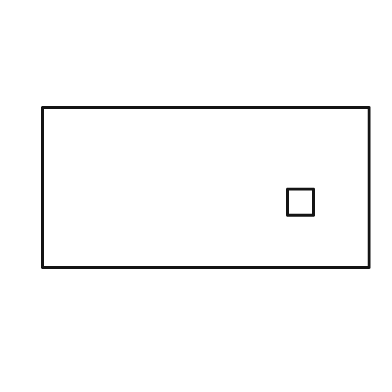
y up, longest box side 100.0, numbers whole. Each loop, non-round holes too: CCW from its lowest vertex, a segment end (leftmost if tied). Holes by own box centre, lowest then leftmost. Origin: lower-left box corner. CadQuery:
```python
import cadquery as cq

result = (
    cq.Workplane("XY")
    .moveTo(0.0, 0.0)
    .lineTo(100.0, 0.0)
    .lineTo(100.0, 49.0)
    .lineTo(0.0, 49.0)
    .close()
    .moveTo(75.0, 16.0)
    .lineTo(83.0, 16.0)
    .lineTo(83.0, 24.0)
    .lineTo(75.0, 24.0)
    .close()
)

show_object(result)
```